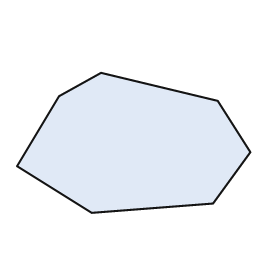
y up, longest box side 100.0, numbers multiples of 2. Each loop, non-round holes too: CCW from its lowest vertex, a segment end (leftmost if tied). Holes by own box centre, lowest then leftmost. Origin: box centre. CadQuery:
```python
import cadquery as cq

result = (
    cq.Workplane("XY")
    .moveTo(-18.0, -30.0)
    .lineTo(34.0, -26.0)
    .lineTo(50.0, -4.0)
    .lineTo(36.0, 18.0)
    .lineTo(-14.0, 30.0)
    .lineTo(-32.0, 20.0)
    .lineTo(-50.0, -10.0)
    .close()
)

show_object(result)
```